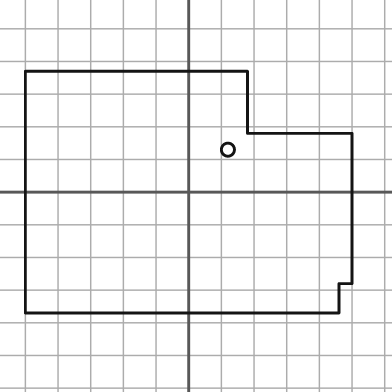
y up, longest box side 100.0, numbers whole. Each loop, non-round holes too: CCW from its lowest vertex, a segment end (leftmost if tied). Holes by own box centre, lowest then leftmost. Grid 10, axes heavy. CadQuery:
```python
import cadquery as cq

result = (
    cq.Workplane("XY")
    .moveTo(-50.0, -37.0)
    .lineTo(46.0, -37.0)
    .lineTo(46.0, -28.0)
    .lineTo(50.0, -28.0)
    .lineTo(50.0, 18.0)
    .lineTo(18.0, 18.0)
    .lineTo(18.0, 37.0)
    .lineTo(-50.0, 37.0)
    .close()
    .moveTo(12.0, 13.0)
    .circle(2.0)
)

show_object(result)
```